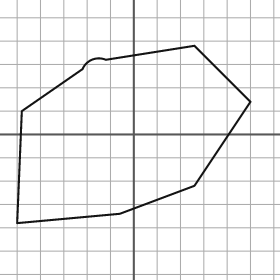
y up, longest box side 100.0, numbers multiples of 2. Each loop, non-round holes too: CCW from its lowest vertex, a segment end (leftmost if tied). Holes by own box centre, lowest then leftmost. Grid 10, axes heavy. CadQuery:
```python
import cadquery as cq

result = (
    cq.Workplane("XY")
    .moveTo(-50.0, -38.0)
    .lineTo(-6.0, -34.0)
    .lineTo(26.0, -22.0)
    .lineTo(50.0, 14.0)
    .lineTo(26.0, 38.0)
    .lineTo(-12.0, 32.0)
    .threePointArc((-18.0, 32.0), (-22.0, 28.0))
    .lineTo(-48.0, 10.0)
    .close()
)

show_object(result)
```